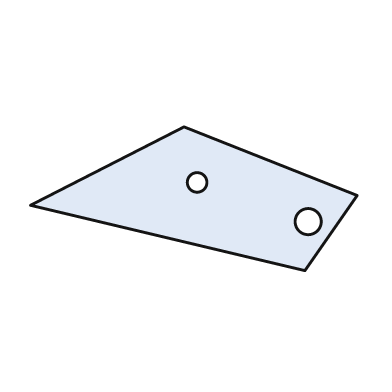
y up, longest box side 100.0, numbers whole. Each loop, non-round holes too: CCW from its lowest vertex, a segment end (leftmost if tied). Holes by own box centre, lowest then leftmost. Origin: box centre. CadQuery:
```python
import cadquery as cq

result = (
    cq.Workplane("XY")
    .moveTo(34.0, -22.0)
    .lineTo(50.0, 1.0)
    .lineTo(-3.0, 22.0)
    .lineTo(-50.0, -2.0)
    .close()
    .moveTo(35.0, -7.0)
    .circle(4.0)
    .moveTo(1.0, 5.0)
    .circle(3.0)
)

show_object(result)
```